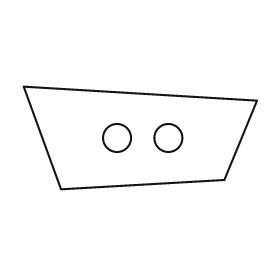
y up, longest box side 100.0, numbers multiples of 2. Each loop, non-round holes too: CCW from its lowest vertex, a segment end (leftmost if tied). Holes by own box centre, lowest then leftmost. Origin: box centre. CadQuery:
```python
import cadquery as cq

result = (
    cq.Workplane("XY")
    .moveTo(-34.0, -22.0)
    .lineTo(36.0, -18.0)
    .lineTo(50.0, 16.0)
    .lineTo(-50.0, 22.0)
    .close()
    .moveTo(-10.0, 0.0)
    .circle(6.0)
    .moveTo(12.0, 0.0)
    .circle(6.0)
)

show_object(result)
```